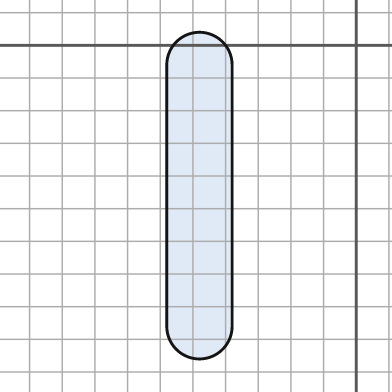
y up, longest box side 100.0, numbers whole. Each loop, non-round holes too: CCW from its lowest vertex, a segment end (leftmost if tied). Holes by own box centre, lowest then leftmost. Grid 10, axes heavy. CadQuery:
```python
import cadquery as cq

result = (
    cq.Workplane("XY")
    .moveTo(-58.0, -86.0)
    .threePointArc((-48.0, -96.0), (-38.0, -86.0))
    .lineTo(-38.0, -6.0)
    .threePointArc((-48.0, 4.0), (-58.0, -6.0))
    .close()
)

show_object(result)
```